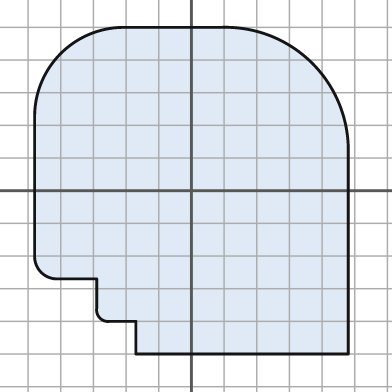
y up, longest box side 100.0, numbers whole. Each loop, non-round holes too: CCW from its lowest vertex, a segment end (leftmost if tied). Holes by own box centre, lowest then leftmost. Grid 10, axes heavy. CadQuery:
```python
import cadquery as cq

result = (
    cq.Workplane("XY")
    .moveTo(-17.0, -50.0)
    .lineTo(48.0, -50.0)
    .lineTo(48.0, 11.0)
    .threePointArc((37.0, 39.0), (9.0, 50.0))
    .lineTo(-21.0, 50.0)
    .threePointArc((-40.0, 42.0), (-48.0, 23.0))
    .lineTo(-48.0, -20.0)
    .threePointArc((-46.0, -25.0), (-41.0, -27.0))
    .lineTo(-29.0, -27.0)
    .lineTo(-29.0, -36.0)
    .threePointArc((-28.0, -39.0), (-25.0, -40.0))
    .lineTo(-17.0, -40.0)
    .close()
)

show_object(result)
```